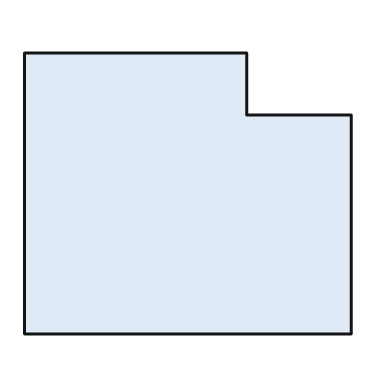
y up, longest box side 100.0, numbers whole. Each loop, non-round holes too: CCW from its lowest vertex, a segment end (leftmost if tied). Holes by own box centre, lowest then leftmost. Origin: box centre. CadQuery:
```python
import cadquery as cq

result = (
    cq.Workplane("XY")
    .moveTo(-50.0, -43.0)
    .lineTo(50.0, -43.0)
    .lineTo(50.0, 24.0)
    .lineTo(18.0, 24.0)
    .lineTo(18.0, 43.0)
    .lineTo(-50.0, 43.0)
    .close()
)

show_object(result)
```